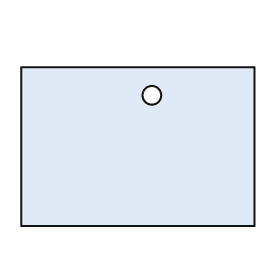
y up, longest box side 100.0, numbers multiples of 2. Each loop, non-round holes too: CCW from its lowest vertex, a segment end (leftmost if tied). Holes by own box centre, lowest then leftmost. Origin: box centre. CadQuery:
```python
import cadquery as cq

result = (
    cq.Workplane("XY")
    .moveTo(-50.0, -34.0)
    .lineTo(50.0, -34.0)
    .lineTo(50.0, 34.0)
    .lineTo(-50.0, 34.0)
    .close()
    .moveTo(6.0, 22.0)
    .circle(4.0)
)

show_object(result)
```